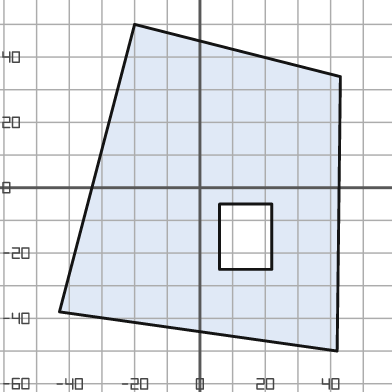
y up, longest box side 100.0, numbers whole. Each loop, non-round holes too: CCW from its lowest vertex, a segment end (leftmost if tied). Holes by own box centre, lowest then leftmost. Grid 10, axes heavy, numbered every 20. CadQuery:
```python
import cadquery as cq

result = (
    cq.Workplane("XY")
    .moveTo(42.0, -50.0)
    .lineTo(43.0, 34.0)
    .lineTo(-20.0, 50.0)
    .lineTo(-43.0, -38.0)
    .close()
    .moveTo(6.0, -25.0)
    .lineTo(22.0, -25.0)
    .lineTo(22.0, -5.0)
    .lineTo(6.0, -5.0)
    .close()
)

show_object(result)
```